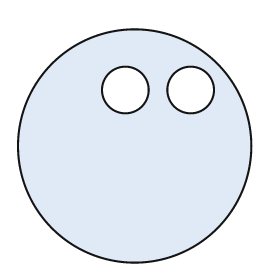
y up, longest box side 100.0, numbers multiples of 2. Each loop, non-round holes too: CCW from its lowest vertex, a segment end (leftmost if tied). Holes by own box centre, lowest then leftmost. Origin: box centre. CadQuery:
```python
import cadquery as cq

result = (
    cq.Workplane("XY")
    .moveTo(0.0, 0.0)
    .circle(50.0)
    .moveTo(-4.0, 24.0)
    .circle(10.0)
    .moveTo(24.0, 24.0)
    .circle(10.0)
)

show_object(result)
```